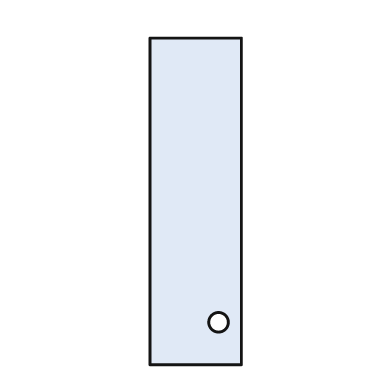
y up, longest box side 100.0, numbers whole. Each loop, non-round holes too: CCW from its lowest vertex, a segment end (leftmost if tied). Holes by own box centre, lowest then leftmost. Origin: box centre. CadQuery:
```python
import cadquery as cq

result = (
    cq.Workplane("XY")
    .moveTo(-14.0, -50.0)
    .lineTo(14.0, -50.0)
    .lineTo(14.0, 50.0)
    .lineTo(-14.0, 50.0)
    .close()
    .moveTo(7.0, -37.0)
    .circle(3.0)
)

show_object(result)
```